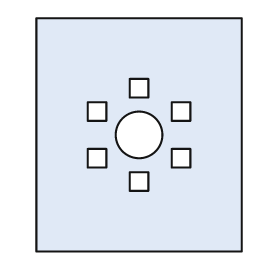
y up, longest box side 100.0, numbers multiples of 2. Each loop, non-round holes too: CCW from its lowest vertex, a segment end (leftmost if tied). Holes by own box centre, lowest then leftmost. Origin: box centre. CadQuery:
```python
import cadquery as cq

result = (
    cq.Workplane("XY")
    .moveTo(-44.0, -50.0)
    .lineTo(44.0, -50.0)
    .lineTo(44.0, 50.0)
    .lineTo(-44.0, 50.0)
    .close()
    .moveTo(-4.0, -24.0)
    .lineTo(4.0, -24.0)
    .lineTo(4.0, -16.0)
    .lineTo(-4.0, -16.0)
    .close()
    .moveTo(-22.0, -14.0)
    .lineTo(-14.0, -14.0)
    .lineTo(-14.0, -6.0)
    .lineTo(-22.0, -6.0)
    .close()
    .moveTo(14.0, -14.0)
    .lineTo(22.0, -14.0)
    .lineTo(22.0, -6.0)
    .lineTo(14.0, -6.0)
    .close()
    .moveTo(0.0, 0.0)
    .circle(10.0)
    .moveTo(-22.0, 6.0)
    .lineTo(-14.0, 6.0)
    .lineTo(-14.0, 14.0)
    .lineTo(-22.0, 14.0)
    .close()
    .moveTo(14.0, 6.0)
    .lineTo(22.0, 6.0)
    .lineTo(22.0, 14.0)
    .lineTo(14.0, 14.0)
    .close()
    .moveTo(-4.0, 16.0)
    .lineTo(4.0, 16.0)
    .lineTo(4.0, 24.0)
    .lineTo(-4.0, 24.0)
    .close()
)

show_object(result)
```